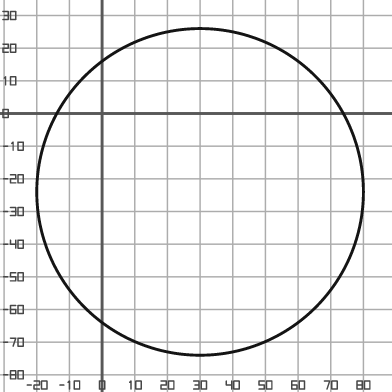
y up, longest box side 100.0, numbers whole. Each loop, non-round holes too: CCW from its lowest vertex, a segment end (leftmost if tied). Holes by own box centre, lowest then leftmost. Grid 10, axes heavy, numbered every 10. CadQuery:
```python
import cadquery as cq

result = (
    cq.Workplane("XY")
    .moveTo(30.0, -24.0)
    .circle(50.0)
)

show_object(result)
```